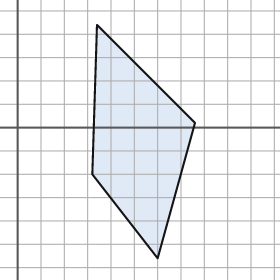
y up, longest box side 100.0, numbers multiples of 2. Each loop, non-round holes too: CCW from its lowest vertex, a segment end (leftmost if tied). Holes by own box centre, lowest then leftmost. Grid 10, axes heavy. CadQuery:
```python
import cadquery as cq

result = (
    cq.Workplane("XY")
    .moveTo(60.0, -56.0)
    .lineTo(76.0, 2.0)
    .lineTo(34.0, 44.0)
    .lineTo(32.0, -20.0)
    .close()
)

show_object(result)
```